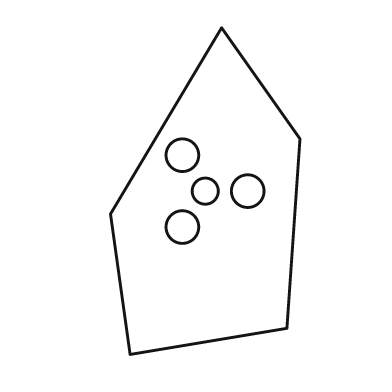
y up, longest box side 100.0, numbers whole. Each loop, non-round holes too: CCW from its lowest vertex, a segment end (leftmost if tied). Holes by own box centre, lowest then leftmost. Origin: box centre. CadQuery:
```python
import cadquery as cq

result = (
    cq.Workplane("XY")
    .moveTo(-23.0, -50.0)
    .lineTo(25.0, -42.0)
    .lineTo(29.0, 16.0)
    .lineTo(5.0, 50.0)
    .lineTo(-29.0, -7.0)
    .close()
    .moveTo(-7.0, -11.0)
    .circle(5.0)
    .moveTo(0.0, 0.0)
    .circle(4.0)
    .moveTo(13.0, 0.0)
    .circle(5.0)
    .moveTo(-7.0, 11.0)
    .circle(5.0)
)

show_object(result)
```